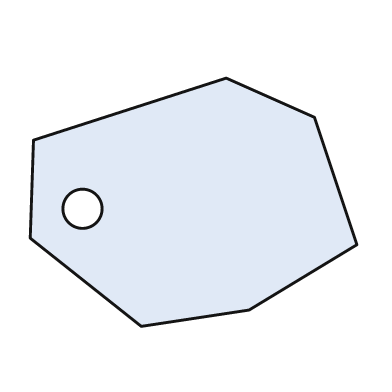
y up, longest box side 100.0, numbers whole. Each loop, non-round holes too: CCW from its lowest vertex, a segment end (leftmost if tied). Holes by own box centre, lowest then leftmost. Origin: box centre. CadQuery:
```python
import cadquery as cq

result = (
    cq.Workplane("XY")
    .moveTo(-16.0, -38.0)
    .lineTo(17.0, -33.0)
    .lineTo(50.0, -13.0)
    .lineTo(37.0, 26.0)
    .lineTo(10.0, 38.0)
    .lineTo(-49.0, 19.0)
    .lineTo(-50.0, -11.0)
    .close()
    .moveTo(-34.0, -2.0)
    .circle(6.0)
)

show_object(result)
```